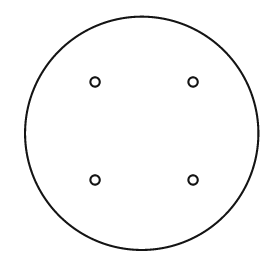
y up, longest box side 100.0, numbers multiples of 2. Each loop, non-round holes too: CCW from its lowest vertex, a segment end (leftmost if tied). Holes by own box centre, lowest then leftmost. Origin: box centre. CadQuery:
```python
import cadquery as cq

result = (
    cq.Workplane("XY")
    .moveTo(0.0, 0.0)
    .circle(50.0)
    .moveTo(-20.0, -20.0)
    .circle(2.0)
    .moveTo(22.0, -20.0)
    .circle(2.0)
    .moveTo(-20.0, 22.0)
    .circle(2.0)
    .moveTo(22.0, 22.0)
    .circle(2.0)
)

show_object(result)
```